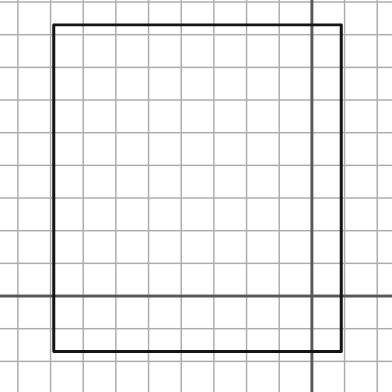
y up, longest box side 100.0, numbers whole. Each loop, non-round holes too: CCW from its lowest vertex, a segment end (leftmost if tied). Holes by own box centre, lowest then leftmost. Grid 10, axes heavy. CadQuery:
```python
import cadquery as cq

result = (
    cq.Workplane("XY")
    .moveTo(-79.0, -17.0)
    .lineTo(9.0, -17.0)
    .lineTo(9.0, 83.0)
    .lineTo(-79.0, 83.0)
    .close()
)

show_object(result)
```